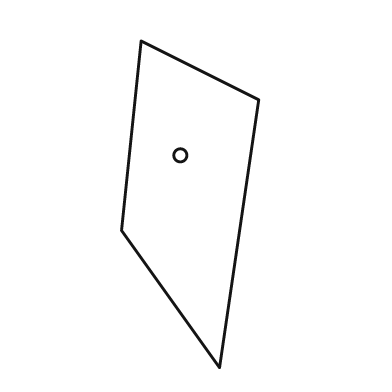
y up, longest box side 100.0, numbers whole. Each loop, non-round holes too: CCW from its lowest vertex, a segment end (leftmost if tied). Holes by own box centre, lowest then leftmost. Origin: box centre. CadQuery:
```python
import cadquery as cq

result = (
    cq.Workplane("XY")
    .moveTo(9.0, -50.0)
    .lineTo(21.0, 32.0)
    .lineTo(-15.0, 50.0)
    .lineTo(-21.0, -8.0)
    .close()
    .moveTo(-3.0, 15.0)
    .circle(2.0)
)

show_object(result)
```